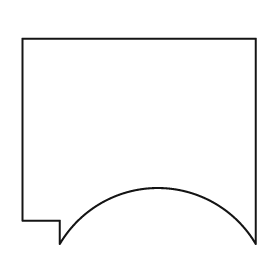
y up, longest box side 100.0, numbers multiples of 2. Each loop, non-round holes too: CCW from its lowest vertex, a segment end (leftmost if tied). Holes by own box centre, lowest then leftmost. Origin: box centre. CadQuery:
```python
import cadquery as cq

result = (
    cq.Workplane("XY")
    .moveTo(-34.0, -44.0)
    .threePointArc((8.0, -20.0), (50.0, -44.0))
    .lineTo(50.0, 44.0)
    .lineTo(-50.0, 44.0)
    .lineTo(-50.0, -34.0)
    .lineTo(-34.0, -34.0)
    .close()
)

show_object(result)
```